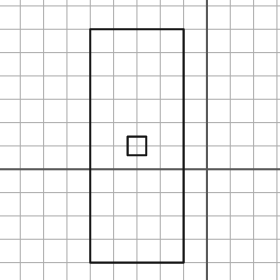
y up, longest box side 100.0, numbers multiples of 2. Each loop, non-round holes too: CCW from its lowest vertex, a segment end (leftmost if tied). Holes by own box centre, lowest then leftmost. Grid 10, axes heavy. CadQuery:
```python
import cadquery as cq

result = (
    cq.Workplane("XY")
    .moveTo(-50.0, -40.0)
    .lineTo(-10.0, -40.0)
    .lineTo(-10.0, 60.0)
    .lineTo(-50.0, 60.0)
    .close()
    .moveTo(-34.0, 6.0)
    .lineTo(-26.0, 6.0)
    .lineTo(-26.0, 14.0)
    .lineTo(-34.0, 14.0)
    .close()
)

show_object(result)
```